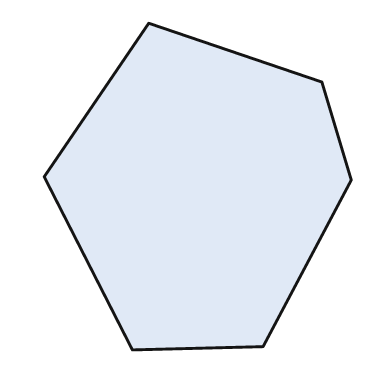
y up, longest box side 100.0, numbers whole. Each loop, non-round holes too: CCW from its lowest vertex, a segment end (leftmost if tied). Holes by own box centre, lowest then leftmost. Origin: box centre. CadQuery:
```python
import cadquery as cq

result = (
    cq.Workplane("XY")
    .moveTo(-20.0, -50.0)
    .lineTo(20.0, -49.0)
    .lineTo(47.0, 2.0)
    .lineTo(38.0, 32.0)
    .lineTo(-15.0, 50.0)
    .lineTo(-47.0, 3.0)
    .close()
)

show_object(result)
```